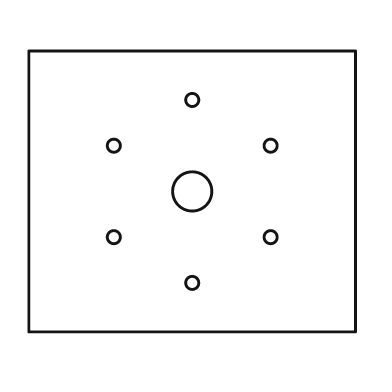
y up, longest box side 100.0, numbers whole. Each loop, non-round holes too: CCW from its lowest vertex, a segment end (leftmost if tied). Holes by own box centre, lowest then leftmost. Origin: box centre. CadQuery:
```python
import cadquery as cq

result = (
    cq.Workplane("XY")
    .moveTo(-50.0, -43.0)
    .lineTo(50.0, -43.0)
    .lineTo(50.0, 43.0)
    .lineTo(-50.0, 43.0)
    .close()
    .moveTo(0.0, -28.0)
    .circle(2.0)
    .moveTo(-24.0, -14.0)
    .circle(2.0)
    .moveTo(24.0, -14.0)
    .circle(2.0)
    .moveTo(0.0, 0.0)
    .circle(6.0)
    .moveTo(-24.0, 14.0)
    .circle(2.0)
    .moveTo(24.0, 14.0)
    .circle(2.0)
    .moveTo(0.0, 28.0)
    .circle(2.0)
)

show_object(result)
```